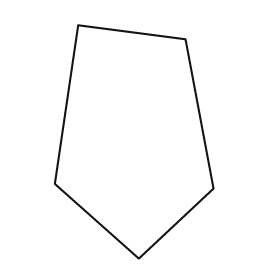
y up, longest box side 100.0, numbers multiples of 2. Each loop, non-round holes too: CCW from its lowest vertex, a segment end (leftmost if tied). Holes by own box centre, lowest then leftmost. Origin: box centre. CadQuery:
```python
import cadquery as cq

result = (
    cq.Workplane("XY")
    .moveTo(2.0, -50.0)
    .lineTo(34.0, -20.0)
    .lineTo(22.0, 44.0)
    .lineTo(-24.0, 50.0)
    .lineTo(-34.0, -18.0)
    .close()
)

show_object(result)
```